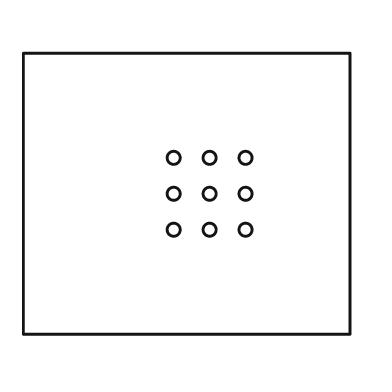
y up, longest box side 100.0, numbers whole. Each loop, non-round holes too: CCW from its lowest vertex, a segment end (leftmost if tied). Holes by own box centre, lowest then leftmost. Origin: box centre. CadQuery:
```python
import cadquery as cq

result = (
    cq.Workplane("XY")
    .moveTo(-50.0, -43.0)
    .lineTo(50.0, -43.0)
    .lineTo(50.0, 43.0)
    .lineTo(-50.0, 43.0)
    .close()
    .moveTo(-4.0, -11.0)
    .circle(2.0)
    .moveTo(7.0, -11.0)
    .circle(2.0)
    .moveTo(18.0, -11.0)
    .circle(2.0)
    .moveTo(-4.0, 0.0)
    .circle(2.0)
    .moveTo(7.0, 0.0)
    .circle(2.0)
    .moveTo(18.0, 0.0)
    .circle(2.0)
    .moveTo(-4.0, 11.0)
    .circle(2.0)
    .moveTo(7.0, 11.0)
    .circle(2.0)
    .moveTo(18.0, 11.0)
    .circle(2.0)
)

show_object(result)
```